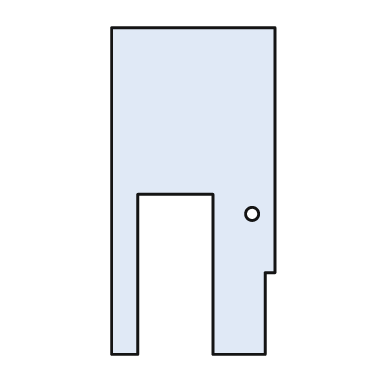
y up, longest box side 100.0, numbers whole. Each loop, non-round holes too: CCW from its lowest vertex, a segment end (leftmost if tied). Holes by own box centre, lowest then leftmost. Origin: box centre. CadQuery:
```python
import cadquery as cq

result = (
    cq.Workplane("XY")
    .moveTo(-25.0, -50.0)
    .lineTo(-17.0, -50.0)
    .lineTo(-17.0, -1.0)
    .lineTo(6.0, -1.0)
    .lineTo(6.0, -50.0)
    .lineTo(22.0, -50.0)
    .lineTo(22.0, -25.0)
    .lineTo(25.0, -25.0)
    .lineTo(25.0, 50.0)
    .lineTo(-25.0, 50.0)
    .close()
    .moveTo(18.0, -7.0)
    .circle(2.0)
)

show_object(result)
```